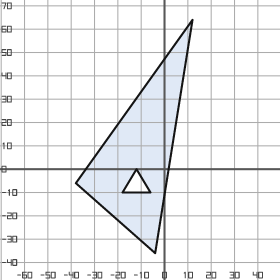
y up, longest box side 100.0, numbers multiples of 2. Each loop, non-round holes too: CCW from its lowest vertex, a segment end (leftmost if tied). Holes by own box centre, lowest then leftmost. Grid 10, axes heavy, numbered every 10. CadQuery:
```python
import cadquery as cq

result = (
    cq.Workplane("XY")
    .moveTo(-4.0, -36.0)
    .lineTo(12.0, 64.0)
    .lineTo(-38.0, -6.0)
    .close()
    .moveTo(-18.0, -10.0)
    .lineTo(-6.0, -10.0)
    .lineTo(-12.0, 0.0)
    .close()
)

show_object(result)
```